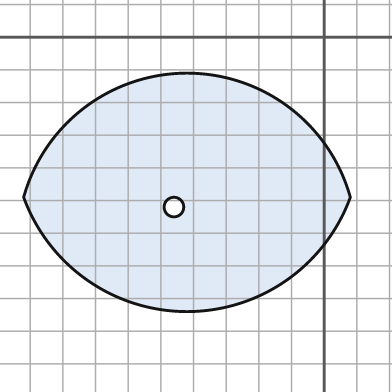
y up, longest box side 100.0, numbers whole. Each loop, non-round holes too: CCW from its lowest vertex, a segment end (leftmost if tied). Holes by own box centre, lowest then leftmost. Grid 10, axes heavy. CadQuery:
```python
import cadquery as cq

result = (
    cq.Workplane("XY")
    .moveTo(-92.0, -49.0)
    .threePointArc((-42.0, -84.0), (8.0, -49.0))
    .threePointArc((-42.0, -11.0), (-92.0, -49.0))
    .close()
    .moveTo(-46.0, -52.0)
    .circle(3.0)
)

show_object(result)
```